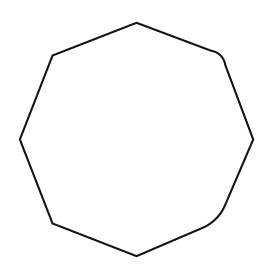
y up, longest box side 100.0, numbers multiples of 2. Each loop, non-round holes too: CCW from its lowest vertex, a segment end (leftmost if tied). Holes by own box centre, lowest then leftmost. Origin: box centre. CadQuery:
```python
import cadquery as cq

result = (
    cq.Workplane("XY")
    .moveTo(0.0, -50.0)
    .lineTo(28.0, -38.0)
    .threePointArc((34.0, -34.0), (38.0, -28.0))
    .lineTo(50.0, 0.0)
    .lineTo(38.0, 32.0)
    .threePointArc((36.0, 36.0), (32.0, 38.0))
    .lineTo(0.0, 50.0)
    .lineTo(-36.0, 36.0)
    .lineTo(-50.0, 0.0)
    .lineTo(-36.0, -36.0)
    .close()
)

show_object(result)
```